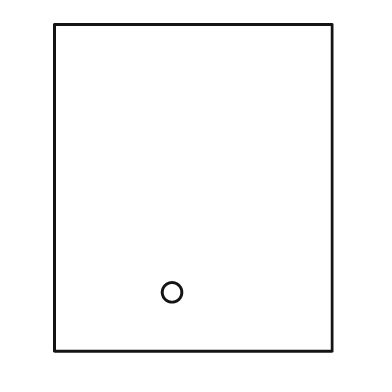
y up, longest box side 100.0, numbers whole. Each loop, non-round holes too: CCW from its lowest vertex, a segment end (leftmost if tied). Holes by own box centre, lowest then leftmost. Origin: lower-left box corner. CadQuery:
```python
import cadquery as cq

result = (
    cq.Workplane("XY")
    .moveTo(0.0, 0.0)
    .lineTo(85.0, 0.0)
    .lineTo(85.0, 100.0)
    .lineTo(0.0, 100.0)
    .close()
    .moveTo(36.0, 18.0)
    .circle(3.0)
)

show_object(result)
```